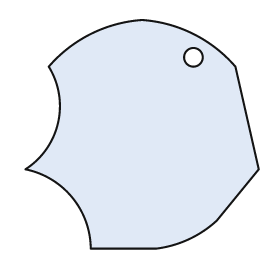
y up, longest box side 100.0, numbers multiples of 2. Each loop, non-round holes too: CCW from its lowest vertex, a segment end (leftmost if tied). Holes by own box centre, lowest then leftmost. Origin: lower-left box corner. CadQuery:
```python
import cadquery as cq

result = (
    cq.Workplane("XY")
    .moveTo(28.0, 0.0)
    .lineTo(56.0, 0.0)
    .threePointArc((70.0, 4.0), (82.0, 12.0))
    .lineTo(100.0, 34.0)
    .lineTo(90.0, 78.0)
    .threePointArc((72.0, 92.0), (50.0, 98.0))
    .threePointArc((28.0, 92.0), (10.0, 78.0))
    .threePointArc((14.0, 54.0), (0.0, 34.0))
    .threePointArc((20.0, 22.0), (28.0, 0.0))
    .close()
    .moveTo(72.0, 82.0)
    .circle(4.0)
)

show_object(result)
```